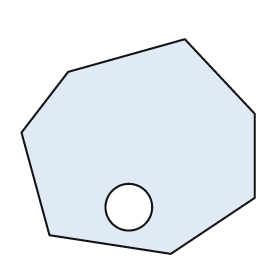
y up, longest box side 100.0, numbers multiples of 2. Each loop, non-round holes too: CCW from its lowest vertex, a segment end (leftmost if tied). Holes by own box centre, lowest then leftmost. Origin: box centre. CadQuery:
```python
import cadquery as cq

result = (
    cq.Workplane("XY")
    .moveTo(14.0, -46.0)
    .lineTo(50.0, -22.0)
    .lineTo(50.0, 14.0)
    .lineTo(20.0, 46.0)
    .lineTo(-30.0, 32.0)
    .lineTo(-50.0, 6.0)
    .lineTo(-38.0, -38.0)
    .close()
    .moveTo(-4.0, -26.0)
    .circle(10.0)
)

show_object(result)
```